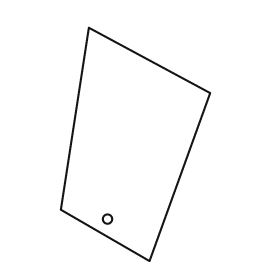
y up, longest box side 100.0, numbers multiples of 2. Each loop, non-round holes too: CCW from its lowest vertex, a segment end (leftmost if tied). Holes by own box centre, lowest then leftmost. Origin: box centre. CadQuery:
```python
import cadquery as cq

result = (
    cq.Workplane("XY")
    .moveTo(6.0, -50.0)
    .lineTo(32.0, 22.0)
    .lineTo(-20.0, 50.0)
    .lineTo(-32.0, -28.0)
    .close()
    .moveTo(-12.0, -32.0)
    .circle(2.0)
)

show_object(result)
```